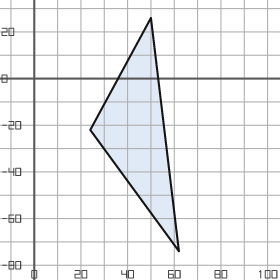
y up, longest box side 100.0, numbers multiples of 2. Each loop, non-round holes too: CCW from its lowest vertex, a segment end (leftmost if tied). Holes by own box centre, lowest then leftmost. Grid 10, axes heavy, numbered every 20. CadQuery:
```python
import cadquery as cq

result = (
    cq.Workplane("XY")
    .moveTo(62.0, -74.0)
    .lineTo(50.0, 26.0)
    .lineTo(24.0, -22.0)
    .close()
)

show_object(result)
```